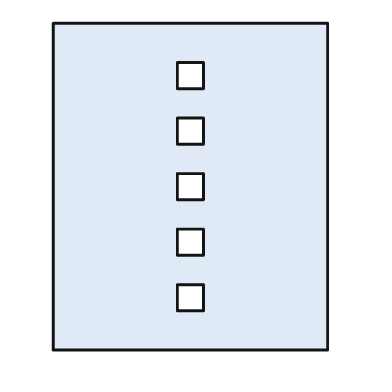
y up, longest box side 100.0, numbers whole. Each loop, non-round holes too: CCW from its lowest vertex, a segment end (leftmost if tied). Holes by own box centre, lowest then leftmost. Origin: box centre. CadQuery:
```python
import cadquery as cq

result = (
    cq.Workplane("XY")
    .moveTo(-42.0, -50.0)
    .lineTo(42.0, -50.0)
    .lineTo(42.0, 50.0)
    .lineTo(-42.0, 50.0)
    .close()
    .moveTo(-4.0, -38.0)
    .lineTo(4.0, -38.0)
    .lineTo(4.0, -30.0)
    .lineTo(-4.0, -30.0)
    .close()
    .moveTo(-4.0, -21.0)
    .lineTo(4.0, -21.0)
    .lineTo(4.0, -13.0)
    .lineTo(-4.0, -13.0)
    .close()
    .moveTo(-4.0, -4.0)
    .lineTo(4.0, -4.0)
    .lineTo(4.0, 4.0)
    .lineTo(-4.0, 4.0)
    .close()
    .moveTo(-4.0, 13.0)
    .lineTo(4.0, 13.0)
    .lineTo(4.0, 21.0)
    .lineTo(-4.0, 21.0)
    .close()
    .moveTo(-4.0, 30.0)
    .lineTo(4.0, 30.0)
    .lineTo(4.0, 38.0)
    .lineTo(-4.0, 38.0)
    .close()
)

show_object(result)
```